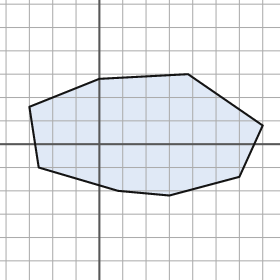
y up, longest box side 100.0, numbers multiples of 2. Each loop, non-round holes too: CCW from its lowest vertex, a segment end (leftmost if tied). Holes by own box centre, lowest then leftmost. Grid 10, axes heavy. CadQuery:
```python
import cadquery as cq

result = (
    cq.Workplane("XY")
    .moveTo(30.0, -22.0)
    .lineTo(60.0, -14.0)
    .lineTo(70.0, 8.0)
    .lineTo(38.0, 30.0)
    .lineTo(0.0, 28.0)
    .lineTo(-30.0, 16.0)
    .lineTo(-26.0, -10.0)
    .lineTo(8.0, -20.0)
    .close()
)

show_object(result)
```